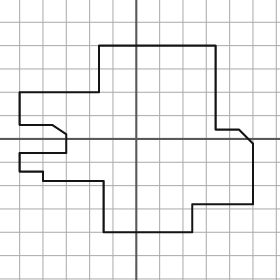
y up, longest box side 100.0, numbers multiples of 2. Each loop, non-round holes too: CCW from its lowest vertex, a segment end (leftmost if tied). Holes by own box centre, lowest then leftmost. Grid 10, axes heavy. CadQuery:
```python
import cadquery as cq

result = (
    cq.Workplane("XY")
    .moveTo(-14.0, -40.0)
    .lineTo(24.0, -40.0)
    .lineTo(24.0, -28.0)
    .lineTo(50.0, -28.0)
    .lineTo(50.0, -2.0)
    .lineTo(44.0, 4.0)
    .lineTo(34.0, 4.0)
    .lineTo(34.0, 40.0)
    .lineTo(-16.0, 40.0)
    .lineTo(-16.0, 20.0)
    .lineTo(-50.0, 20.0)
    .lineTo(-50.0, 6.0)
    .lineTo(-36.0, 6.0)
    .lineTo(-30.0, 2.0)
    .lineTo(-30.0, -6.0)
    .lineTo(-50.0, -6.0)
    .lineTo(-50.0, -14.0)
    .lineTo(-40.0, -14.0)
    .lineTo(-40.0, -18.0)
    .lineTo(-14.0, -18.0)
    .close()
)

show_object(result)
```